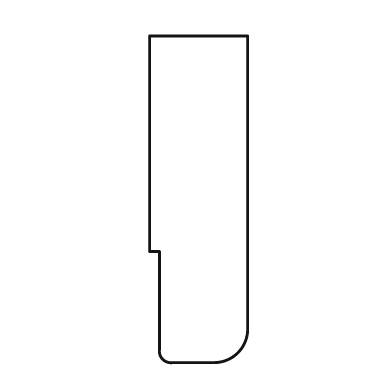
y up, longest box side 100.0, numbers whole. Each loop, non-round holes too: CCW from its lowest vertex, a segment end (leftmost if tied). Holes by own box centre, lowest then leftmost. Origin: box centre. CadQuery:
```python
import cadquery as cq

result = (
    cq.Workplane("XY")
    .moveTo(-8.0, -50.0)
    .lineTo(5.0, -50.0)
    .threePointArc((12.0, -47.0), (15.0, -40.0))
    .lineTo(15.0, 50.0)
    .lineTo(-15.0, 50.0)
    .lineTo(-15.0, -16.0)
    .lineTo(-12.0, -16.0)
    .lineTo(-12.0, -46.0)
    .threePointArc((-11.0, -49.0), (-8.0, -50.0))
    .close()
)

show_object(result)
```